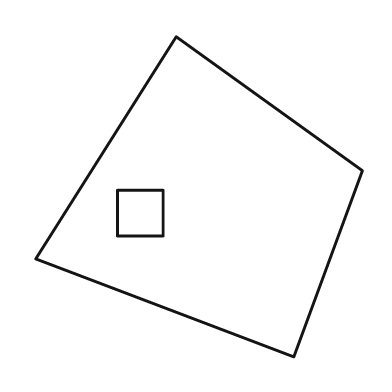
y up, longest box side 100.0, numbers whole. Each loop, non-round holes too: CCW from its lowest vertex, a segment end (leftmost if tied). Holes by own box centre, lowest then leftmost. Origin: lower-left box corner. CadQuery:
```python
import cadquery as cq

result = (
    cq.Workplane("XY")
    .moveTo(79.0, 0.0)
    .lineTo(100.0, 57.0)
    .lineTo(43.0, 98.0)
    .lineTo(0.0, 30.0)
    .close()
    .moveTo(25.0, 37.0)
    .lineTo(39.0, 37.0)
    .lineTo(39.0, 51.0)
    .lineTo(25.0, 51.0)
    .close()
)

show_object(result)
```